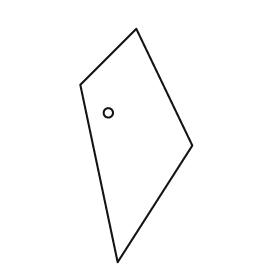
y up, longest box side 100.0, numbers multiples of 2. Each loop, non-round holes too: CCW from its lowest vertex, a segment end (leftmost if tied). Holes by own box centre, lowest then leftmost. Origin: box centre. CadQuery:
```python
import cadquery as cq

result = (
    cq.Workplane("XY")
    .moveTo(-8.0, -50.0)
    .lineTo(24.0, 0.0)
    .lineTo(0.0, 50.0)
    .lineTo(-24.0, 26.0)
    .close()
    .moveTo(-12.0, 14.0)
    .circle(2.0)
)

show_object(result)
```